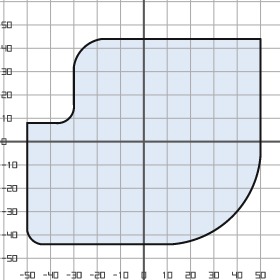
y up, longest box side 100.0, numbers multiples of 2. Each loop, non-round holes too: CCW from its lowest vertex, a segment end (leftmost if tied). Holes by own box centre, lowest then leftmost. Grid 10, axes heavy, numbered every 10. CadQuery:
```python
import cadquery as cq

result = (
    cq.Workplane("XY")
    .moveTo(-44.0, -44.0)
    .lineTo(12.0, -44.0)
    .threePointArc((38.0, -32.0), (50.0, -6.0))
    .lineTo(50.0, 44.0)
    .lineTo(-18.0, 44.0)
    .threePointArc((-26.0, 40.0), (-30.0, 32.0))
    .lineTo(-30.0, 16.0)
    .threePointArc((-32.0, 10.0), (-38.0, 8.0))
    .lineTo(-50.0, 8.0)
    .lineTo(-50.0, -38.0)
    .threePointArc((-48.0, -42.0), (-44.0, -44.0))
    .close()
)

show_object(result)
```